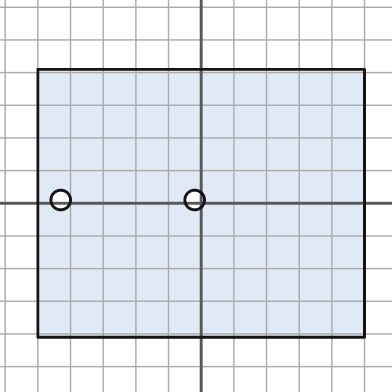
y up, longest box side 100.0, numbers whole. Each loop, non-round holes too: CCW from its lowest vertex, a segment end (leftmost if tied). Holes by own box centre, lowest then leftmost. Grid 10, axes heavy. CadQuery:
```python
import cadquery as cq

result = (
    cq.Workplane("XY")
    .moveTo(-50.0, -41.0)
    .lineTo(50.0, -41.0)
    .lineTo(50.0, 41.0)
    .lineTo(-50.0, 41.0)
    .close()
    .moveTo(-43.0, 1.0)
    .circle(3.0)
    .moveTo(-2.0, 1.0)
    .circle(3.0)
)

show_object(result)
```